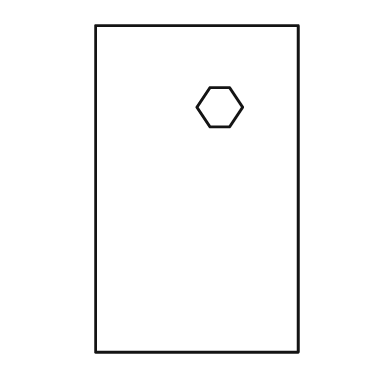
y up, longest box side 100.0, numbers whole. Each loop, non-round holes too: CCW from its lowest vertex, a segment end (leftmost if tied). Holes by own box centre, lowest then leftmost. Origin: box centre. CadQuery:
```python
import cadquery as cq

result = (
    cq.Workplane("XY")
    .moveTo(-31.0, -50.0)
    .lineTo(31.0, -50.0)
    .lineTo(31.0, 50.0)
    .lineTo(-31.0, 50.0)
    .close()
    .moveTo(4.0, 19.0)
    .lineTo(10.0, 19.0)
    .lineTo(14.0, 25.0)
    .lineTo(10.0, 31.0)
    .lineTo(4.0, 31.0)
    .lineTo(0.0, 25.0)
    .close()
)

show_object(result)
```